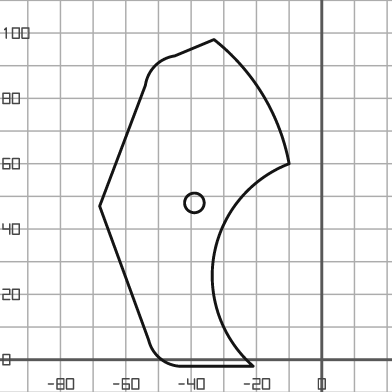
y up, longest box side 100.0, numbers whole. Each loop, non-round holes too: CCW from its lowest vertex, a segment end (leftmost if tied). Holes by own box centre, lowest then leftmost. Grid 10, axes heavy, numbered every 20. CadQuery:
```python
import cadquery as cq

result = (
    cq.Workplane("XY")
    .moveTo(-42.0, -2.0)
    .lineTo(-21.0, -2.0)
    .threePointArc((-33.0, 32.0), (-10.0, 60.0))
    .threePointArc((-18.0, 81.0), (-33.0, 98.0))
    .lineTo(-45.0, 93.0)
    .threePointArc((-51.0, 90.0), (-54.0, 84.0))
    .lineTo(-68.0, 47.0)
    .lineTo(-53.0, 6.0)
    .threePointArc((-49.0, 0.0), (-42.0, -2.0))
    .close()
    .moveTo(-39.0, 48.0)
    .circle(3.0)
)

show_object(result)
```